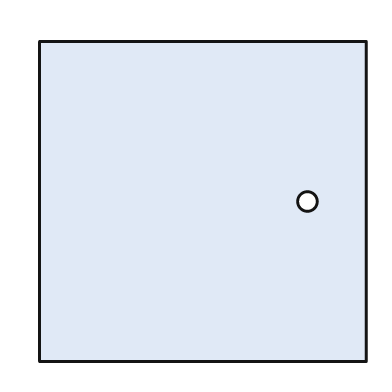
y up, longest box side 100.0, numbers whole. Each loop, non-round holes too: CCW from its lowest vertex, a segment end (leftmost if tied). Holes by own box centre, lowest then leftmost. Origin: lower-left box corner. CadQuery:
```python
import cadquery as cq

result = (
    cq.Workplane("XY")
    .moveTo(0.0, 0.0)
    .lineTo(100.0, 0.0)
    .lineTo(100.0, 98.0)
    .lineTo(0.0, 98.0)
    .close()
    .moveTo(82.0, 49.0)
    .circle(3.0)
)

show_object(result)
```